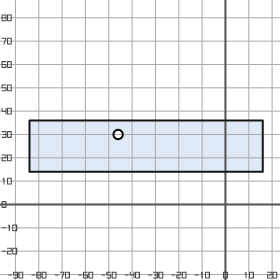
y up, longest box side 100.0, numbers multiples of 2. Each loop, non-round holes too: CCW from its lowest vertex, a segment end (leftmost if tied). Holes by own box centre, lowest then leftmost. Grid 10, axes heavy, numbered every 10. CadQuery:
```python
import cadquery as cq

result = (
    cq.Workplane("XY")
    .moveTo(-84.0, 14.0)
    .lineTo(16.0, 14.0)
    .lineTo(16.0, 36.0)
    .lineTo(-84.0, 36.0)
    .close()
    .moveTo(-46.0, 30.0)
    .circle(2.0)
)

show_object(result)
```